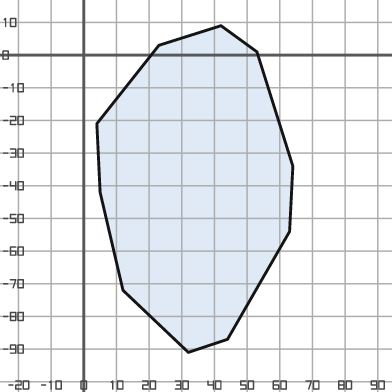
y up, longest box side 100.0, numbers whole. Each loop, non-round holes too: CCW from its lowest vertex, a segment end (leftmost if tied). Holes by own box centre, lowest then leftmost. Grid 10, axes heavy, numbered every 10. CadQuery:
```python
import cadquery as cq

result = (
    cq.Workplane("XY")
    .moveTo(32.0, -91.0)
    .lineTo(44.0, -87.0)
    .lineTo(63.0, -54.0)
    .lineTo(64.0, -34.0)
    .lineTo(53.0, 1.0)
    .lineTo(42.0, 9.0)
    .lineTo(23.0, 3.0)
    .lineTo(4.0, -21.0)
    .lineTo(5.0, -42.0)
    .lineTo(12.0, -72.0)
    .close()
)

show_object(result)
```